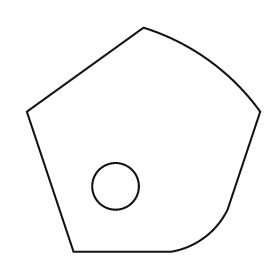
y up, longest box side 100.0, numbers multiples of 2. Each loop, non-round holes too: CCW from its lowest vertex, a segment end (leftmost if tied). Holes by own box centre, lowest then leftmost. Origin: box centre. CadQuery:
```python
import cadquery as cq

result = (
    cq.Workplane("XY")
    .moveTo(-30.0, -48.0)
    .lineTo(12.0, -48.0)
    .threePointArc((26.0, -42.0), (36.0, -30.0))
    .lineTo(50.0, 12.0)
    .threePointArc((28.0, 34.0), (0.0, 48.0))
    .lineTo(-50.0, 12.0)
    .close()
    .moveTo(-12.0, -20.0)
    .circle(10.0)
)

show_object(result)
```